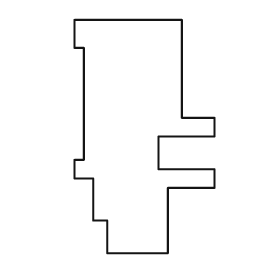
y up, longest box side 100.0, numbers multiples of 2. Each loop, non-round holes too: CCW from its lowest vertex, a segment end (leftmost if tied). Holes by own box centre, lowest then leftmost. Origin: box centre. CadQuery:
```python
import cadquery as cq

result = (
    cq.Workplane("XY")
    .moveTo(-16.0, -50.0)
    .lineTo(10.0, -50.0)
    .lineTo(10.0, -22.0)
    .lineTo(30.0, -22.0)
    .lineTo(30.0, -14.0)
    .lineTo(6.0, -14.0)
    .lineTo(6.0, 0.0)
    .lineTo(30.0, 0.0)
    .lineTo(30.0, 8.0)
    .lineTo(16.0, 8.0)
    .lineTo(16.0, 50.0)
    .lineTo(-30.0, 50.0)
    .lineTo(-30.0, 38.0)
    .lineTo(-26.0, 38.0)
    .lineTo(-26.0, -10.0)
    .lineTo(-30.0, -10.0)
    .lineTo(-30.0, -18.0)
    .lineTo(-22.0, -18.0)
    .lineTo(-22.0, -36.0)
    .lineTo(-16.0, -36.0)
    .close()
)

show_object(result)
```